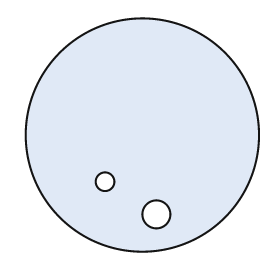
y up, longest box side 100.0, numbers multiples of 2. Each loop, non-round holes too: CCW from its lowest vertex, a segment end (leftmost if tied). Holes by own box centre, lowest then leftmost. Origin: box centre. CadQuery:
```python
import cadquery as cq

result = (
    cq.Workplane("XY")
    .moveTo(0.0, 0.0)
    .circle(50.0)
    .moveTo(6.0, -34.0)
    .circle(6.0)
    .moveTo(-16.0, -20.0)
    .circle(4.0)
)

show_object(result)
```